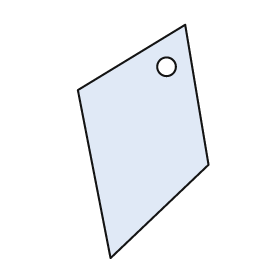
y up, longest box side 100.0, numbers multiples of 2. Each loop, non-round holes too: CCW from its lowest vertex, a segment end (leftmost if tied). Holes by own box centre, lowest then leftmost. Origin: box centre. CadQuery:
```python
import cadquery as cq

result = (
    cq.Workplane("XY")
    .moveTo(-14.0, -50.0)
    .lineTo(28.0, -10.0)
    .lineTo(18.0, 50.0)
    .lineTo(-28.0, 22.0)
    .close()
    .moveTo(10.0, 32.0)
    .circle(4.0)
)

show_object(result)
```